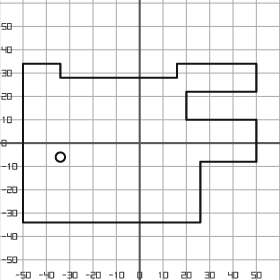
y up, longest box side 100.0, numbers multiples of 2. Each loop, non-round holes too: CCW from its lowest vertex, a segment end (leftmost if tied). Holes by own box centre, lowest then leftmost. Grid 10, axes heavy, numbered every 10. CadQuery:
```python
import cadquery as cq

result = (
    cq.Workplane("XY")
    .moveTo(-50.0, -34.0)
    .lineTo(26.0, -34.0)
    .lineTo(26.0, -8.0)
    .lineTo(50.0, -8.0)
    .lineTo(50.0, 10.0)
    .lineTo(20.0, 10.0)
    .lineTo(20.0, 22.0)
    .lineTo(50.0, 22.0)
    .lineTo(50.0, 34.0)
    .lineTo(16.0, 34.0)
    .lineTo(16.0, 28.0)
    .lineTo(-34.0, 28.0)
    .lineTo(-34.0, 34.0)
    .lineTo(-50.0, 34.0)
    .close()
    .moveTo(-34.0, -6.0)
    .circle(2.0)
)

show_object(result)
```